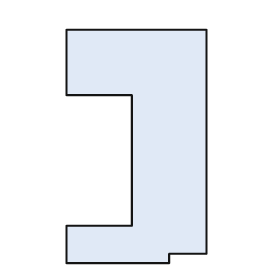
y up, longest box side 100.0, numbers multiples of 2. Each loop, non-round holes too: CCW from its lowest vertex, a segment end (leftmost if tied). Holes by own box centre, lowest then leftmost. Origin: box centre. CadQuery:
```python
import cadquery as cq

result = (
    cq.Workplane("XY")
    .moveTo(-30.0, -50.0)
    .lineTo(14.0, -50.0)
    .lineTo(14.0, -46.0)
    .lineTo(30.0, -46.0)
    .lineTo(30.0, 50.0)
    .lineTo(-30.0, 50.0)
    .lineTo(-30.0, 22.0)
    .lineTo(-2.0, 22.0)
    .lineTo(-2.0, -34.0)
    .lineTo(-30.0, -34.0)
    .close()
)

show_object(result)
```